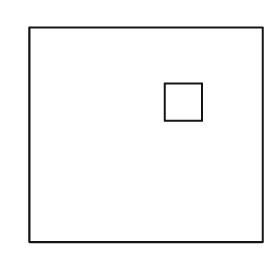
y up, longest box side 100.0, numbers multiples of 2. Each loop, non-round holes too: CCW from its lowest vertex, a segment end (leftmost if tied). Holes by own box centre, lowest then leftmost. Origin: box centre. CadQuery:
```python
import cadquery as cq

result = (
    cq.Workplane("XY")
    .moveTo(-50.0, -46.0)
    .lineTo(50.0, -46.0)
    .lineTo(50.0, 46.0)
    .lineTo(-50.0, 46.0)
    .close()
    .moveTo(8.0, 6.0)
    .lineTo(24.0, 6.0)
    .lineTo(24.0, 22.0)
    .lineTo(8.0, 22.0)
    .close()
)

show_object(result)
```